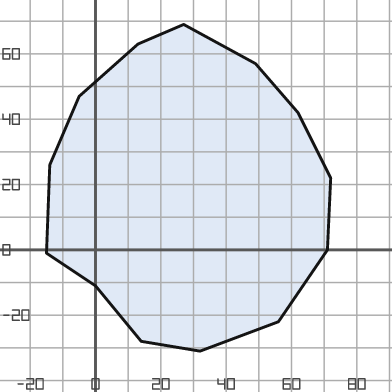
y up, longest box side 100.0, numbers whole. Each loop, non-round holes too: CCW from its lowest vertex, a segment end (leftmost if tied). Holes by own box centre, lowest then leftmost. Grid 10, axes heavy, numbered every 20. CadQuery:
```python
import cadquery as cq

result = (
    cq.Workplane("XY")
    .moveTo(32.0, -31.0)
    .lineTo(56.0, -22.0)
    .lineTo(71.0, 0.0)
    .lineTo(72.0, 22.0)
    .lineTo(62.0, 42.0)
    .lineTo(49.0, 57.0)
    .lineTo(27.0, 69.0)
    .lineTo(13.0, 63.0)
    .lineTo(-5.0, 47.0)
    .lineTo(-14.0, 26.0)
    .lineTo(-15.0, -1.0)
    .lineTo(0.0, -11.0)
    .lineTo(14.0, -28.0)
    .close()
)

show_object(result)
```